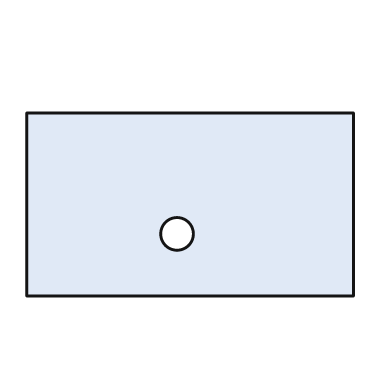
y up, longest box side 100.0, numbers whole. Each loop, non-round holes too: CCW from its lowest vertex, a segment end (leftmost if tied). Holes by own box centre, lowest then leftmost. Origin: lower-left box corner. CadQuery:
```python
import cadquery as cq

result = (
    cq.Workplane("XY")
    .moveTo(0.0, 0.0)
    .lineTo(100.0, 0.0)
    .lineTo(100.0, 56.0)
    .lineTo(0.0, 56.0)
    .close()
    .moveTo(46.0, 19.0)
    .circle(5.0)
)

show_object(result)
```